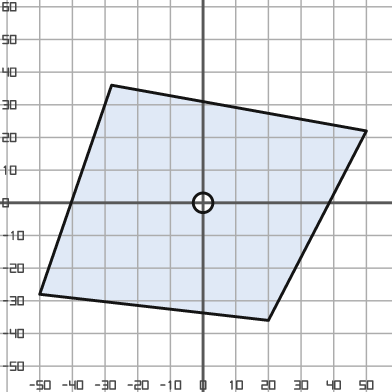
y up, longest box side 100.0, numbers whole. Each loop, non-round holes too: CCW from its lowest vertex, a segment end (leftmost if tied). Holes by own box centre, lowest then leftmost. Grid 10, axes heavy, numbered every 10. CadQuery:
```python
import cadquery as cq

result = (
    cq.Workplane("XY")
    .moveTo(20.0, -36.0)
    .lineTo(50.0, 22.0)
    .lineTo(-28.0, 36.0)
    .lineTo(-50.0, -28.0)
    .close()
    .moveTo(0.0, 0.0)
    .circle(3.0)
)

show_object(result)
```